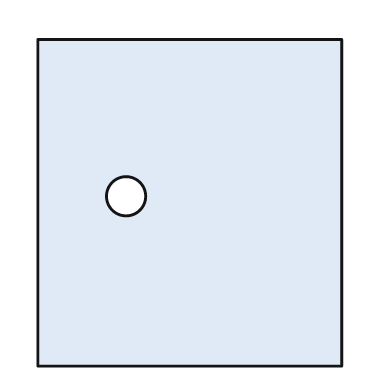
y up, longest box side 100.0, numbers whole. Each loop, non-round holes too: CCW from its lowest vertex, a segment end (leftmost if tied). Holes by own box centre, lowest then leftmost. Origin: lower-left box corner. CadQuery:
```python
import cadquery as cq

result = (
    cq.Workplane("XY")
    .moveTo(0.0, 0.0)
    .lineTo(93.0, 0.0)
    .lineTo(93.0, 100.0)
    .lineTo(0.0, 100.0)
    .close()
    .moveTo(27.0, 52.0)
    .circle(6.0)
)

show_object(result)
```